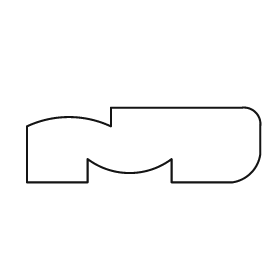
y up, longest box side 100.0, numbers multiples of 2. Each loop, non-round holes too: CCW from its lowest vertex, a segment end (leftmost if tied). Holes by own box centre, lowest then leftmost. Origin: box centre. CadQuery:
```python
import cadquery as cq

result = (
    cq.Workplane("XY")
    .moveTo(-50.0, -16.0)
    .lineTo(-24.0, -16.0)
    .lineTo(-24.0, -6.0)
    .threePointArc((-6.0, -12.0), (12.0, -6.0))
    .lineTo(12.0, -16.0)
    .lineTo(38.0, -16.0)
    .threePointArc((46.0, -12.0), (50.0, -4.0))
    .lineTo(50.0, 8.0)
    .threePointArc((48.0, 14.0), (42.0, 16.0))
    .lineTo(-14.0, 16.0)
    .lineTo(-14.0, 8.0)
    .threePointArc((-32.0, 12.0), (-50.0, 8.0))
    .close()
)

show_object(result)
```